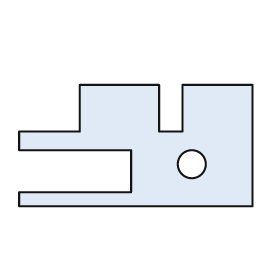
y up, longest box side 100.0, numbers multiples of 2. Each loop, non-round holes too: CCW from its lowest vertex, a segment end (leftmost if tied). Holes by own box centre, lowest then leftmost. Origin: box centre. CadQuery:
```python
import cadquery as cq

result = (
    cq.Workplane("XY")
    .moveTo(-50.0, -26.0)
    .lineTo(50.0, -26.0)
    .lineTo(50.0, 26.0)
    .lineTo(20.0, 26.0)
    .lineTo(20.0, 6.0)
    .lineTo(10.0, 6.0)
    .lineTo(10.0, 26.0)
    .lineTo(-24.0, 26.0)
    .lineTo(-24.0, 6.0)
    .lineTo(-50.0, 6.0)
    .lineTo(-50.0, -2.0)
    .lineTo(-2.0, -2.0)
    .lineTo(-2.0, -20.0)
    .lineTo(-50.0, -20.0)
    .close()
    .moveTo(24.0, -8.0)
    .circle(6.0)
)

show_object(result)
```